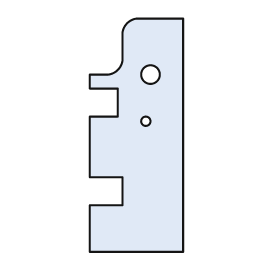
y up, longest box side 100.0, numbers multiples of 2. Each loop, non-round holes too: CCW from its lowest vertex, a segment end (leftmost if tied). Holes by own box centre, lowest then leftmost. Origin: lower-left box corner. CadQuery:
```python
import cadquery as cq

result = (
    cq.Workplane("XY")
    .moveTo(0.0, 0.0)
    .lineTo(40.0, 0.0)
    .lineTo(40.0, 100.0)
    .lineTo(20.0, 100.0)
    .threePointArc((16.0, 98.0), (14.0, 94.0))
    .lineTo(14.0, 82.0)
    .threePointArc((12.0, 78.0), (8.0, 76.0))
    .lineTo(0.0, 76.0)
    .lineTo(0.0, 70.0)
    .lineTo(12.0, 70.0)
    .lineTo(12.0, 58.0)
    .lineTo(0.0, 58.0)
    .lineTo(0.0, 32.0)
    .lineTo(14.0, 32.0)
    .lineTo(14.0, 20.0)
    .lineTo(0.0, 20.0)
    .close()
    .moveTo(24.0, 56.0)
    .circle(2.0)
    .moveTo(26.0, 76.0)
    .circle(4.0)
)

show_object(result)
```